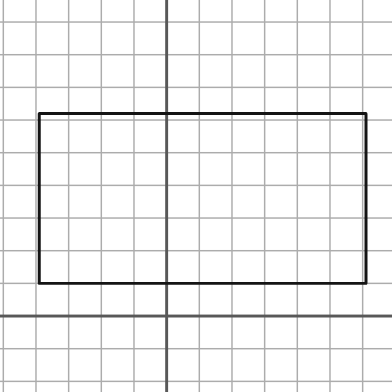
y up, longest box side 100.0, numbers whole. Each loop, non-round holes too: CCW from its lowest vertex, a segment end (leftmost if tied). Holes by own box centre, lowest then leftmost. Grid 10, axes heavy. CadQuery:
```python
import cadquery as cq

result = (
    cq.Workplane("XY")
    .moveTo(-39.0, 10.0)
    .lineTo(61.0, 10.0)
    .lineTo(61.0, 62.0)
    .lineTo(-39.0, 62.0)
    .close()
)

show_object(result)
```